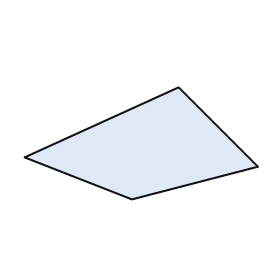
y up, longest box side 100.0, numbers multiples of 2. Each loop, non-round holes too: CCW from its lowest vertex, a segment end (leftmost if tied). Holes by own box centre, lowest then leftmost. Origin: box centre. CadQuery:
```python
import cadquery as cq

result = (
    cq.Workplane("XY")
    .moveTo(-4.0, -24.0)
    .lineTo(50.0, -10.0)
    .lineTo(16.0, 24.0)
    .lineTo(-50.0, -6.0)
    .close()
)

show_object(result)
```